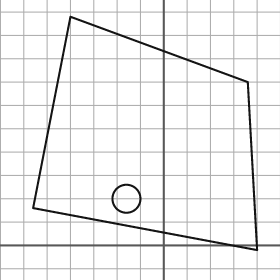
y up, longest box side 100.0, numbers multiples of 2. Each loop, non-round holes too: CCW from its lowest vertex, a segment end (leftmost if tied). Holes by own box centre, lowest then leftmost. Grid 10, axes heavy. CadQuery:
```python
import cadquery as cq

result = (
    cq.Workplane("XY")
    .moveTo(40.0, -2.0)
    .lineTo(36.0, 70.0)
    .lineTo(-40.0, 98.0)
    .lineTo(-56.0, 16.0)
    .close()
    .moveTo(-16.0, 20.0)
    .circle(6.0)
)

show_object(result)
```